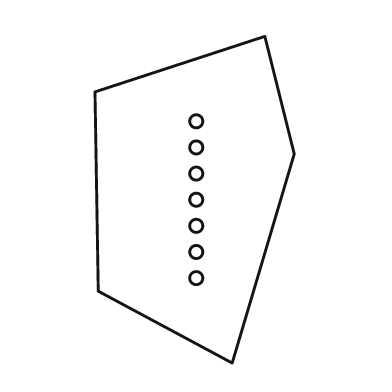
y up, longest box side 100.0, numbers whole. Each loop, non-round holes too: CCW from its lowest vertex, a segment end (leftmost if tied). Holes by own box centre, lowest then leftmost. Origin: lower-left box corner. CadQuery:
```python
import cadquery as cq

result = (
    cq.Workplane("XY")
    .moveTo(42.0, 0.0)
    .lineTo(61.0, 64.0)
    .lineTo(52.0, 100.0)
    .lineTo(0.0, 83.0)
    .lineTo(1.0, 22.0)
    .close()
    .moveTo(31.0, 26.0)
    .circle(2.0)
    .moveTo(31.0, 34.0)
    .circle(2.0)
    .moveTo(31.0, 42.0)
    .circle(2.0)
    .moveTo(31.0, 50.0)
    .circle(2.0)
    .moveTo(31.0, 58.0)
    .circle(2.0)
    .moveTo(31.0, 66.0)
    .circle(2.0)
    .moveTo(31.0, 74.0)
    .circle(2.0)
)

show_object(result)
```